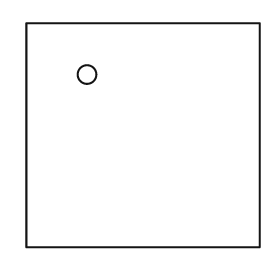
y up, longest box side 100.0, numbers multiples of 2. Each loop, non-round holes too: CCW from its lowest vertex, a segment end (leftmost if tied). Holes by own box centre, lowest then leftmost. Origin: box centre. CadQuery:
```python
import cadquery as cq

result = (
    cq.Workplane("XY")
    .moveTo(-50.0, -48.0)
    .lineTo(50.0, -48.0)
    .lineTo(50.0, 48.0)
    .lineTo(-50.0, 48.0)
    .close()
    .moveTo(-24.0, 26.0)
    .circle(4.0)
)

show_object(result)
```